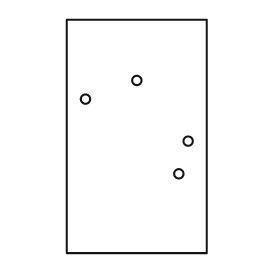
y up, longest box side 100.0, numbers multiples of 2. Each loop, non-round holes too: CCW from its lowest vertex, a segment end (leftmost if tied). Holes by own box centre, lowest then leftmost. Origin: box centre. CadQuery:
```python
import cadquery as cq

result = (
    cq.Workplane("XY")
    .moveTo(-30.0, -50.0)
    .lineTo(30.0, -50.0)
    .lineTo(30.0, 50.0)
    .lineTo(-30.0, 50.0)
    .close()
    .moveTo(18.0, -16.0)
    .circle(2.0)
    .moveTo(22.0, -2.0)
    .circle(2.0)
    .moveTo(-22.0, 16.0)
    .circle(2.0)
    .moveTo(0.0, 24.0)
    .circle(2.0)
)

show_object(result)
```